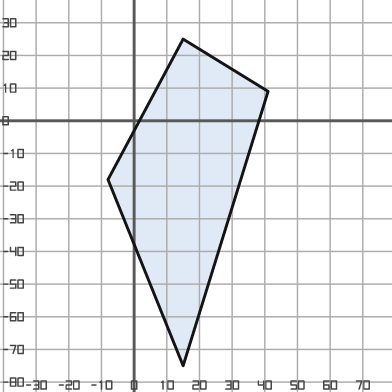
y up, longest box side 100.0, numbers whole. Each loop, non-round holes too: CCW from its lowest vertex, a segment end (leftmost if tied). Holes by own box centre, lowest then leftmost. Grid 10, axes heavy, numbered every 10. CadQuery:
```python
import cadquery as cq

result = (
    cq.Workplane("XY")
    .moveTo(15.0, -75.0)
    .lineTo(41.0, 9.0)
    .lineTo(15.0, 25.0)
    .lineTo(-8.0, -18.0)
    .close()
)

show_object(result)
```